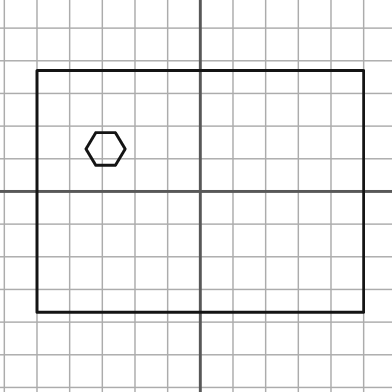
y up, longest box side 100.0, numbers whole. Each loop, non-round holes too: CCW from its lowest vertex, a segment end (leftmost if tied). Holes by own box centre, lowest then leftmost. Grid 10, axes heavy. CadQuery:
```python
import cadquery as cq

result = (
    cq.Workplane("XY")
    .moveTo(-50.0, -37.0)
    .lineTo(50.0, -37.0)
    .lineTo(50.0, 37.0)
    .lineTo(-50.0, 37.0)
    .close()
    .moveTo(-32.0, 8.0)
    .lineTo(-26.0, 8.0)
    .lineTo(-23.0, 13.0)
    .lineTo(-26.0, 18.0)
    .lineTo(-32.0, 18.0)
    .lineTo(-35.0, 13.0)
    .close()
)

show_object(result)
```